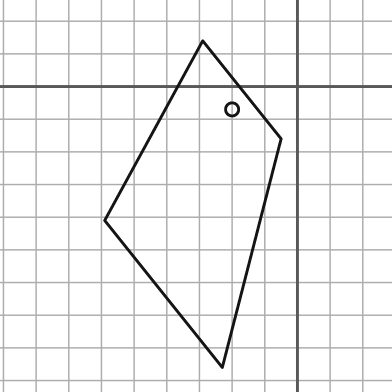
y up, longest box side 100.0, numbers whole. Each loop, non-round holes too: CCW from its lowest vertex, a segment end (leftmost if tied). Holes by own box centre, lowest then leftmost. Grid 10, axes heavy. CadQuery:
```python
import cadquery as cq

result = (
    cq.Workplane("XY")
    .moveTo(-23.0, -86.0)
    .lineTo(-5.0, -16.0)
    .lineTo(-29.0, 14.0)
    .lineTo(-59.0, -41.0)
    .close()
    .moveTo(-20.0, -7.0)
    .circle(2.0)
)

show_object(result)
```